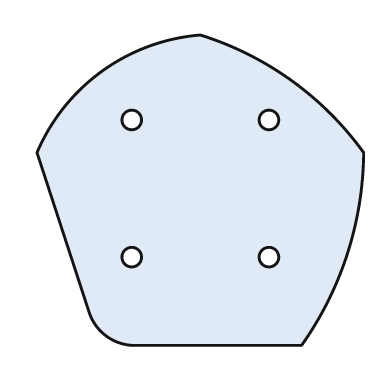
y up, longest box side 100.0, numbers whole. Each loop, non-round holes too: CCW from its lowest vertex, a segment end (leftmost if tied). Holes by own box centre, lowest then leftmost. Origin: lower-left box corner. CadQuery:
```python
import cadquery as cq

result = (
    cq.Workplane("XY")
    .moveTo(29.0, 0.0)
    .lineTo(81.0, 0.0)
    .threePointArc((95.0, 28.0), (100.0, 59.0))
    .threePointArc((78.0, 81.0), (50.0, 95.0))
    .threePointArc((20.0, 84.0), (0.0, 59.0))
    .lineTo(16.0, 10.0)
    .threePointArc((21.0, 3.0), (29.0, 0.0))
    .close()
    .moveTo(29.0, 27.0)
    .circle(3.0)
    .moveTo(71.0, 27.0)
    .circle(3.0)
    .moveTo(29.0, 69.0)
    .circle(3.0)
    .moveTo(71.0, 69.0)
    .circle(3.0)
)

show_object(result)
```